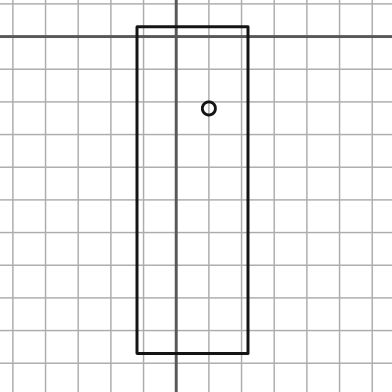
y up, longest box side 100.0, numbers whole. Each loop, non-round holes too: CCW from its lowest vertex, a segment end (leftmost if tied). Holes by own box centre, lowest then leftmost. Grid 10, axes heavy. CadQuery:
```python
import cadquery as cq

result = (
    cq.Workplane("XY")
    .moveTo(-12.0, -97.0)
    .lineTo(22.0, -97.0)
    .lineTo(22.0, 3.0)
    .lineTo(-12.0, 3.0)
    .close()
    .moveTo(10.0, -22.0)
    .circle(2.0)
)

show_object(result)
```